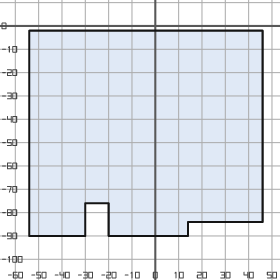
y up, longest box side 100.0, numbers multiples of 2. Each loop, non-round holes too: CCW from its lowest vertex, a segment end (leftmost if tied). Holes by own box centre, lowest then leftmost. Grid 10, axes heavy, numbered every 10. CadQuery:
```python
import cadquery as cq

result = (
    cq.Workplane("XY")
    .moveTo(-54.0, -90.0)
    .lineTo(-30.0, -90.0)
    .lineTo(-30.0, -76.0)
    .lineTo(-20.0, -76.0)
    .lineTo(-20.0, -90.0)
    .lineTo(14.0, -90.0)
    .lineTo(14.0, -84.0)
    .lineTo(46.0, -84.0)
    .lineTo(46.0, -2.0)
    .lineTo(-54.0, -2.0)
    .close()
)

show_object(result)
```